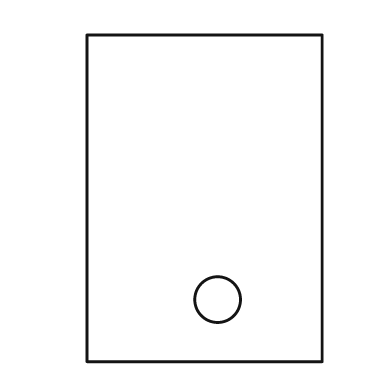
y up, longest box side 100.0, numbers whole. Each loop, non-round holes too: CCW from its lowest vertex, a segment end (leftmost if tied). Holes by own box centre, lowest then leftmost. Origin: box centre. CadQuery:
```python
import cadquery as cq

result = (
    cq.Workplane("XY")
    .moveTo(-36.0, -50.0)
    .lineTo(36.0, -50.0)
    .lineTo(36.0, 50.0)
    .lineTo(-36.0, 50.0)
    .close()
    .moveTo(4.0, -31.0)
    .circle(7.0)
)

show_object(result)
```